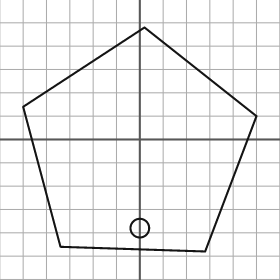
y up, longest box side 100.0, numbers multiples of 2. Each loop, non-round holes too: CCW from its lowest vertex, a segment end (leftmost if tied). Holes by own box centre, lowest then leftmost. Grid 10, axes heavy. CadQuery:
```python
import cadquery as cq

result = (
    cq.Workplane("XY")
    .moveTo(28.0, -48.0)
    .lineTo(50.0, 10.0)
    .lineTo(2.0, 48.0)
    .lineTo(-50.0, 14.0)
    .lineTo(-34.0, -46.0)
    .close()
    .moveTo(0.0, -38.0)
    .circle(4.0)
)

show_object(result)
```